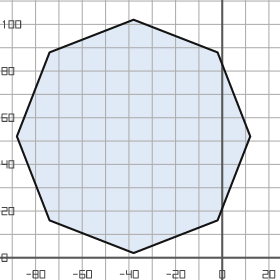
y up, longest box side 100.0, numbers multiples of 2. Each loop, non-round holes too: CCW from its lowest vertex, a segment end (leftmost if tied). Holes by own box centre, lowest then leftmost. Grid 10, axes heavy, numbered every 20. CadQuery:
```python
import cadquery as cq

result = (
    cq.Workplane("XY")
    .moveTo(-38.0, 2.0)
    .lineTo(-2.0, 16.0)
    .lineTo(12.0, 52.0)
    .lineTo(-2.0, 88.0)
    .lineTo(-38.0, 102.0)
    .lineTo(-74.0, 88.0)
    .lineTo(-88.0, 52.0)
    .lineTo(-74.0, 16.0)
    .close()
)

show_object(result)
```